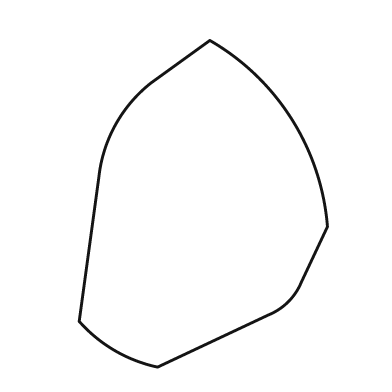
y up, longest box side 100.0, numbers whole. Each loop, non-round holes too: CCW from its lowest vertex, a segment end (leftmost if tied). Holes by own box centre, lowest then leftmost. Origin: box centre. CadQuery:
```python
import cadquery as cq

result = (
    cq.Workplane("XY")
    .moveTo(-14.0, -50.0)
    .lineTo(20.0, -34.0)
    .threePointArc((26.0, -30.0), (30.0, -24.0))
    .lineTo(38.0, -7.0)
    .threePointArc((27.0, 26.0), (2.0, 50.0))
    .lineTo(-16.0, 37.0)
    .threePointArc((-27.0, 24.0), (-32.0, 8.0))
    .lineTo(-38.0, -36.0)
    .threePointArc((-27.0, -45.0), (-14.0, -50.0))
    .close()
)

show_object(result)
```